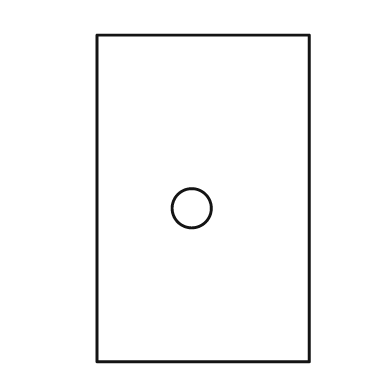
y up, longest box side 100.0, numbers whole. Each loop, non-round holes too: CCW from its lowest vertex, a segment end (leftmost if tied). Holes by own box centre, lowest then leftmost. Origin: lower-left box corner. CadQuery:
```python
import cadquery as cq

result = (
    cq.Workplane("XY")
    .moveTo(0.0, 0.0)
    .lineTo(65.0, 0.0)
    .lineTo(65.0, 100.0)
    .lineTo(0.0, 100.0)
    .close()
    .moveTo(29.0, 47.0)
    .circle(6.0)
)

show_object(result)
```